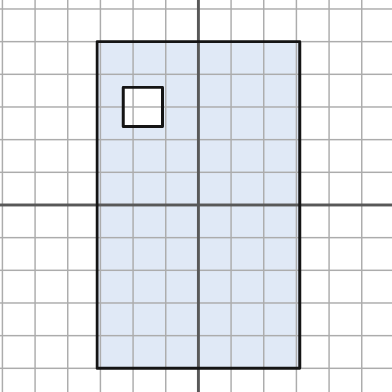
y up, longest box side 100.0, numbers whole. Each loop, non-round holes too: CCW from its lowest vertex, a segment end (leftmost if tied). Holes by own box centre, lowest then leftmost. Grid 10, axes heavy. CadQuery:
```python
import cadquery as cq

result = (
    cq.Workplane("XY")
    .moveTo(-31.0, -50.0)
    .lineTo(31.0, -50.0)
    .lineTo(31.0, 50.0)
    .lineTo(-31.0, 50.0)
    .close()
    .moveTo(-23.0, 24.0)
    .lineTo(-11.0, 24.0)
    .lineTo(-11.0, 36.0)
    .lineTo(-23.0, 36.0)
    .close()
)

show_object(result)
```